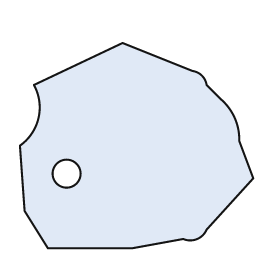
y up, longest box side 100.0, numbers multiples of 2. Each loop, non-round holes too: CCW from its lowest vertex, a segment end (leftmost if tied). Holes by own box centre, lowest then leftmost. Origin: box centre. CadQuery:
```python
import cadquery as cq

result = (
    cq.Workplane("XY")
    .moveTo(-38.0, -44.0)
    .lineTo(-2.0, -44.0)
    .lineTo(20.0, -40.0)
    .threePointArc((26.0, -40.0), (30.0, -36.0))
    .lineTo(50.0, -14.0)
    .lineTo(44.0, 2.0)
    .threePointArc((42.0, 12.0), (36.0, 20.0))
    .lineTo(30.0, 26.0)
    .threePointArc((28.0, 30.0), (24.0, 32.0))
    .lineTo(-6.0, 44.0)
    .lineTo(-44.0, 26.0)
    .threePointArc((-42.0, 12.0), (-50.0, 0.0))
    .lineTo(-48.0, -28.0)
    .close()
    .moveTo(-30.0, -12.0)
    .circle(6.0)
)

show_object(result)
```